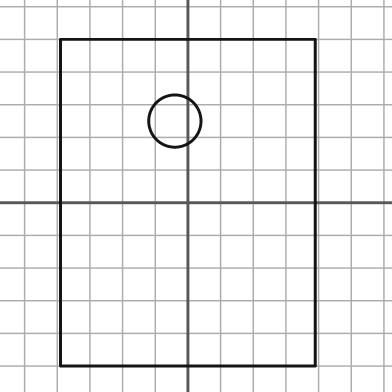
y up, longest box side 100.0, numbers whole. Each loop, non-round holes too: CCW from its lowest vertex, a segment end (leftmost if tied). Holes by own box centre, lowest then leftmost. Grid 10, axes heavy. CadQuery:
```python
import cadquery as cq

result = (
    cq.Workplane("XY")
    .moveTo(-39.0, -50.0)
    .lineTo(39.0, -50.0)
    .lineTo(39.0, 50.0)
    .lineTo(-39.0, 50.0)
    .close()
    .moveTo(-4.0, 25.0)
    .circle(8.0)
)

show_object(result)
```